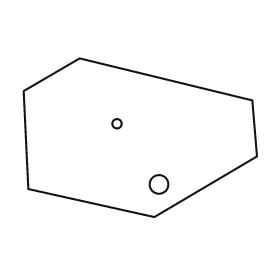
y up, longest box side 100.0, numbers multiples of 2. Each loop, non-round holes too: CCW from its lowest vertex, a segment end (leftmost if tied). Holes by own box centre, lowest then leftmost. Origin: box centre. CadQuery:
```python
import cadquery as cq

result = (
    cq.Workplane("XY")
    .moveTo(6.0, -34.0)
    .lineTo(50.0, -8.0)
    .lineTo(48.0, 16.0)
    .lineTo(-26.0, 34.0)
    .lineTo(-50.0, 20.0)
    .lineTo(-48.0, -22.0)
    .close()
    .moveTo(8.0, -20.0)
    .circle(4.0)
    .moveTo(-10.0, 6.0)
    .circle(2.0)
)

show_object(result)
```